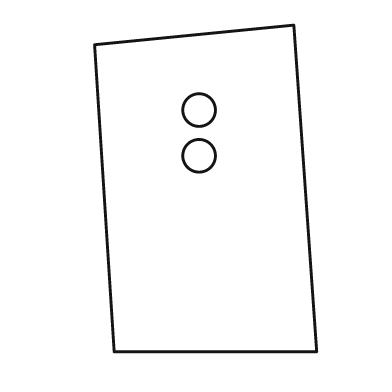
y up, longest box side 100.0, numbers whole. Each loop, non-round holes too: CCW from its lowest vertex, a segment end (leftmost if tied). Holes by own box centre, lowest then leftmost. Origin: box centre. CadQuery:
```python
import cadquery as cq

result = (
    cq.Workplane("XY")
    .moveTo(-28.0, -50.0)
    .lineTo(34.0, -50.0)
    .lineTo(27.0, 50.0)
    .lineTo(-34.0, 44.0)
    .close()
    .moveTo(-2.0, 10.0)
    .circle(5.0)
    .moveTo(-2.0, 24.0)
    .circle(5.0)
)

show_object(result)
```